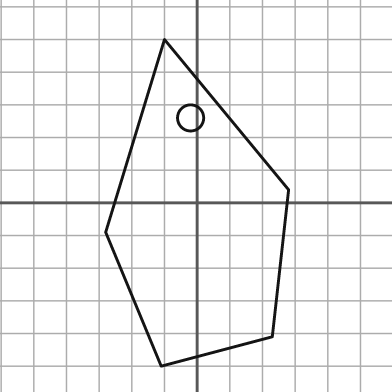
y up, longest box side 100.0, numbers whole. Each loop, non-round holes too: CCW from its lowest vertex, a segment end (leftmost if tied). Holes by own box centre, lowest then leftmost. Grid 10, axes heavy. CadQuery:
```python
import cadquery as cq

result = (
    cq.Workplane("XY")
    .moveTo(-11.0, -50.0)
    .lineTo(23.0, -41.0)
    .lineTo(28.0, 4.0)
    .lineTo(-10.0, 50.0)
    .lineTo(-28.0, -9.0)
    .close()
    .moveTo(-2.0, 26.0)
    .circle(4.0)
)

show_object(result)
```